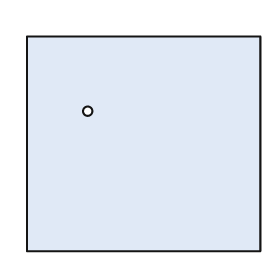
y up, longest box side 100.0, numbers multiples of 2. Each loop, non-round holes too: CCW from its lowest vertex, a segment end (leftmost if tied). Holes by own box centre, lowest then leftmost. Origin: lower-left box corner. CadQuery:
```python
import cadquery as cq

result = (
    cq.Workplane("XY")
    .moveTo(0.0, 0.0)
    .lineTo(100.0, 0.0)
    .lineTo(100.0, 92.0)
    .lineTo(0.0, 92.0)
    .close()
    .moveTo(26.0, 60.0)
    .circle(2.0)
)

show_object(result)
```